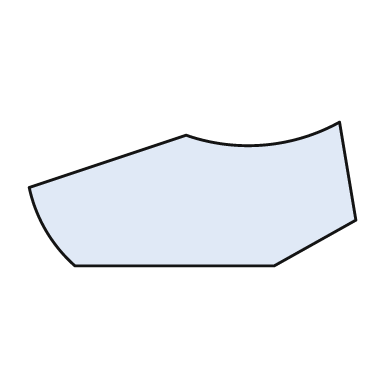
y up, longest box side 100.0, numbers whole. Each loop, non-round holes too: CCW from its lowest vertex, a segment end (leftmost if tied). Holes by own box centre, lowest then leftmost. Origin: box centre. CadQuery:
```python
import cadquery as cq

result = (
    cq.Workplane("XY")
    .moveTo(-36.0, -22.0)
    .lineTo(25.0, -22.0)
    .lineTo(50.0, -8.0)
    .lineTo(45.0, 22.0)
    .threePointArc((22.0, 15.0), (-2.0, 18.0))
    .lineTo(-50.0, 2.0)
    .threePointArc((-45.0, -11.0), (-36.0, -22.0))
    .close()
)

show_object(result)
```